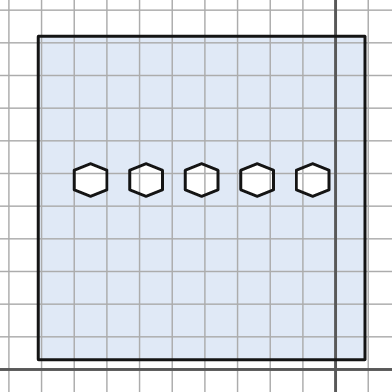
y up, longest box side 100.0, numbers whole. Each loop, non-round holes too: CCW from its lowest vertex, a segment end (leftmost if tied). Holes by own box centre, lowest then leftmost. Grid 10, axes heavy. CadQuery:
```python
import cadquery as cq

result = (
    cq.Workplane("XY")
    .moveTo(-91.0, 3.0)
    .lineTo(9.0, 3.0)
    .lineTo(9.0, 102.0)
    .lineTo(-91.0, 102.0)
    .close()
    .moveTo(-75.0, 53.0)
    .lineTo(-70.0, 55.0)
    .lineTo(-70.0, 61.0)
    .lineTo(-75.0, 63.0)
    .lineTo(-80.0, 61.0)
    .lineTo(-80.0, 55.0)
    .close()
    .moveTo(-58.0, 53.0)
    .lineTo(-53.0, 55.0)
    .lineTo(-53.0, 61.0)
    .lineTo(-58.0, 63.0)
    .lineTo(-63.0, 61.0)
    .lineTo(-63.0, 55.0)
    .close()
    .moveTo(-41.0, 53.0)
    .lineTo(-36.0, 55.0)
    .lineTo(-36.0, 61.0)
    .lineTo(-41.0, 63.0)
    .lineTo(-46.0, 61.0)
    .lineTo(-46.0, 55.0)
    .close()
    .moveTo(-24.0, 53.0)
    .lineTo(-19.0, 55.0)
    .lineTo(-19.0, 61.0)
    .lineTo(-24.0, 63.0)
    .lineTo(-29.0, 61.0)
    .lineTo(-29.0, 55.0)
    .close()
    .moveTo(-7.0, 53.0)
    .lineTo(-2.0, 55.0)
    .lineTo(-2.0, 61.0)
    .lineTo(-7.0, 63.0)
    .lineTo(-12.0, 61.0)
    .lineTo(-12.0, 55.0)
    .close()
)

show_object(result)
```